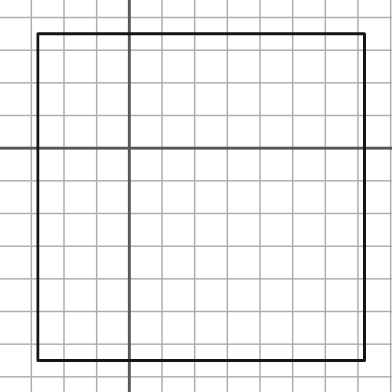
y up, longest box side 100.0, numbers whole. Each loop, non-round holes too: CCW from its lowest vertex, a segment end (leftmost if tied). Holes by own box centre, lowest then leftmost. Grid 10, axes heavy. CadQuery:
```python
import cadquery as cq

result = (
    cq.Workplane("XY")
    .moveTo(-28.0, -65.0)
    .lineTo(72.0, -65.0)
    .lineTo(72.0, 35.0)
    .lineTo(-28.0, 35.0)
    .close()
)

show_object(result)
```